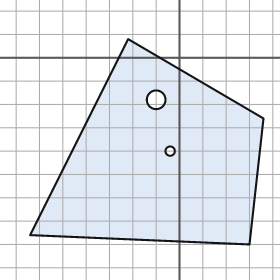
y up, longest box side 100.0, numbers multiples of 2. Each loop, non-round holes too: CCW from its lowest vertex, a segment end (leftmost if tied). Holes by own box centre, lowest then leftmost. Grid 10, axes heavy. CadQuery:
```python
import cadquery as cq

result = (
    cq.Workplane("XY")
    .moveTo(30.0, -80.0)
    .lineTo(36.0, -26.0)
    .lineTo(-22.0, 8.0)
    .lineTo(-64.0, -76.0)
    .close()
    .moveTo(-4.0, -40.0)
    .circle(2.0)
    .moveTo(-10.0, -18.0)
    .circle(4.0)
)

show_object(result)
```